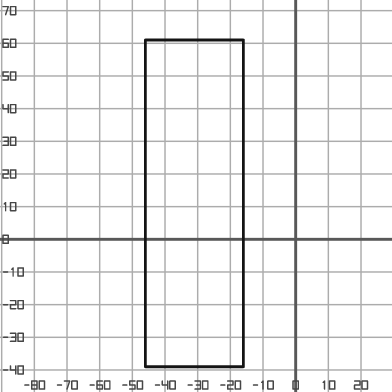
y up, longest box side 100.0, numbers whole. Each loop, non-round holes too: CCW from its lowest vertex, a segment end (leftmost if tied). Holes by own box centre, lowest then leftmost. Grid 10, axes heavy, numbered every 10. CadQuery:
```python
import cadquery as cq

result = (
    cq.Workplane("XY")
    .moveTo(-46.0, -39.0)
    .lineTo(-16.0, -39.0)
    .lineTo(-16.0, 61.0)
    .lineTo(-46.0, 61.0)
    .close()
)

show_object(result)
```